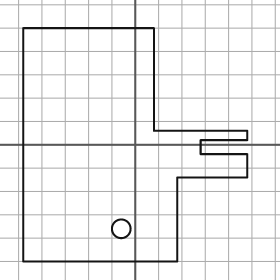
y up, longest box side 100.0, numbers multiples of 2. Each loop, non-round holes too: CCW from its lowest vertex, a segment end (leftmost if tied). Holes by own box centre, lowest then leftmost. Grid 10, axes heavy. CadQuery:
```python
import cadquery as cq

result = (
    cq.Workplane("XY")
    .moveTo(-48.0, -50.0)
    .lineTo(18.0, -50.0)
    .lineTo(18.0, -14.0)
    .lineTo(48.0, -14.0)
    .lineTo(48.0, -4.0)
    .lineTo(28.0, -4.0)
    .lineTo(28.0, 2.0)
    .lineTo(48.0, 2.0)
    .lineTo(48.0, 6.0)
    .lineTo(8.0, 6.0)
    .lineTo(8.0, 50.0)
    .lineTo(-48.0, 50.0)
    .close()
    .moveTo(-6.0, -36.0)
    .circle(4.0)
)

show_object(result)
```